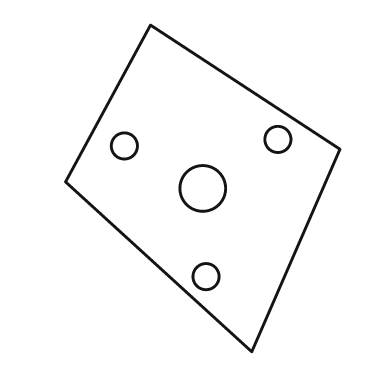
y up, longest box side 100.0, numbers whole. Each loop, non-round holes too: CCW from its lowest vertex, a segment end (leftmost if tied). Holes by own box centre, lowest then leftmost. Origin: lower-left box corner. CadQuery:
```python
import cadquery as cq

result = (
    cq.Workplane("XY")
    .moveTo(57.0, 0.0)
    .lineTo(84.0, 62.0)
    .lineTo(26.0, 100.0)
    .lineTo(0.0, 52.0)
    .close()
    .moveTo(43.0, 23.0)
    .circle(4.0)
    .moveTo(42.0, 50.0)
    .circle(7.0)
    .moveTo(18.0, 63.0)
    .circle(4.0)
    .moveTo(65.0, 65.0)
    .circle(4.0)
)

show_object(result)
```